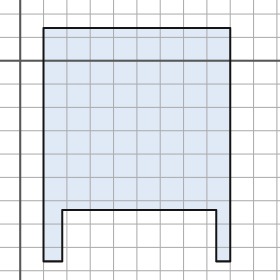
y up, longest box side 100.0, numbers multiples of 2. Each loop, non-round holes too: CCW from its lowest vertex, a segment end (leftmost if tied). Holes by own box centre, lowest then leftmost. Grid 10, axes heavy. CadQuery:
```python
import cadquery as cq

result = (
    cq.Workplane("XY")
    .moveTo(10.0, -86.0)
    .lineTo(18.0, -86.0)
    .lineTo(18.0, -64.0)
    .lineTo(84.0, -64.0)
    .lineTo(84.0, -86.0)
    .lineTo(90.0, -86.0)
    .lineTo(90.0, 14.0)
    .lineTo(10.0, 14.0)
    .close()
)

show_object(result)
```